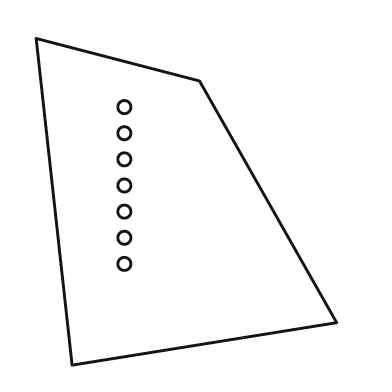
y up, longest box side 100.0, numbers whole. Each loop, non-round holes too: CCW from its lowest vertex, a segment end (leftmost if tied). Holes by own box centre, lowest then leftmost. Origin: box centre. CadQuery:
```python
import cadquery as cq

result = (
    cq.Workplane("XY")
    .moveTo(-35.0, -50.0)
    .lineTo(46.0, -37.0)
    .lineTo(4.0, 37.0)
    .lineTo(-46.0, 50.0)
    .close()
    .moveTo(-19.0, -19.0)
    .circle(2.0)
    .moveTo(-19.0, -11.0)
    .circle(2.0)
    .moveTo(-19.0, -3.0)
    .circle(2.0)
    .moveTo(-19.0, 5.0)
    .circle(2.0)
    .moveTo(-19.0, 13.0)
    .circle(2.0)
    .moveTo(-19.0, 21.0)
    .circle(2.0)
    .moveTo(-19.0, 29.0)
    .circle(2.0)
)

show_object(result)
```